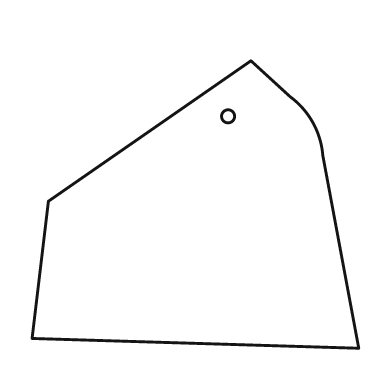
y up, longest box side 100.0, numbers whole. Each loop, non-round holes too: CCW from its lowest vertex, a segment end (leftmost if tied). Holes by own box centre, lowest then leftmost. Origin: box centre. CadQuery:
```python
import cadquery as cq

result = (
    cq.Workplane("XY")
    .moveTo(50.0, -44.0)
    .lineTo(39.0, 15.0)
    .threePointArc((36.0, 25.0), (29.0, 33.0))
    .lineTo(17.0, 44.0)
    .lineTo(-45.0, 1.0)
    .lineTo(-50.0, -41.0)
    .close()
    .moveTo(10.0, 27.0)
    .circle(2.0)
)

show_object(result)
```